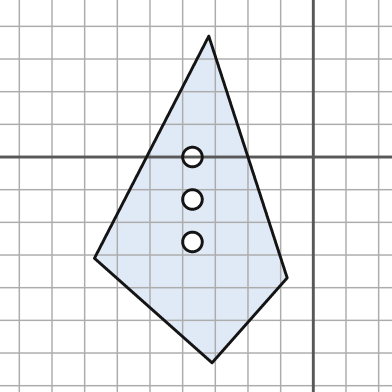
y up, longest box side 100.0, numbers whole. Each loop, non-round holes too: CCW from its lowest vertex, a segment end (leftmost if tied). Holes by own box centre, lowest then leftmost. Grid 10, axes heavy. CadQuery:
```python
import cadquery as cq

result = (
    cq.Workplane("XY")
    .moveTo(-31.0, -63.0)
    .lineTo(-8.0, -37.0)
    .lineTo(-32.0, 37.0)
    .lineTo(-67.0, -31.0)
    .close()
    .moveTo(-37.0, -26.0)
    .circle(3.0)
    .moveTo(-37.0, -13.0)
    .circle(3.0)
    .moveTo(-37.0, 0.0)
    .circle(3.0)
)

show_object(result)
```